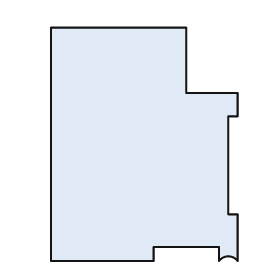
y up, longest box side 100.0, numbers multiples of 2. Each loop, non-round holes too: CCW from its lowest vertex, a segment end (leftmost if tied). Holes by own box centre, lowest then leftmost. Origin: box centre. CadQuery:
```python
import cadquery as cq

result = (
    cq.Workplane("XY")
    .moveTo(-40.0, -50.0)
    .lineTo(4.0, -50.0)
    .lineTo(4.0, -44.0)
    .lineTo(32.0, -44.0)
    .lineTo(32.0, -50.0)
    .threePointArc((36.0, -48.0), (40.0, -50.0))
    .lineTo(40.0, -30.0)
    .lineTo(36.0, -30.0)
    .lineTo(36.0, 12.0)
    .lineTo(40.0, 12.0)
    .lineTo(40.0, 22.0)
    .lineTo(18.0, 22.0)
    .lineTo(18.0, 50.0)
    .lineTo(-40.0, 50.0)
    .close()
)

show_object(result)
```